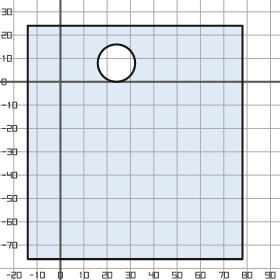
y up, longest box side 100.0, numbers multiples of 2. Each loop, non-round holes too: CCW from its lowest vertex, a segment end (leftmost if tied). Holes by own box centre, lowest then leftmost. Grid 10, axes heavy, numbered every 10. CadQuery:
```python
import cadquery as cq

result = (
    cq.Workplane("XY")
    .moveTo(-14.0, -76.0)
    .lineTo(78.0, -76.0)
    .lineTo(78.0, 24.0)
    .lineTo(-14.0, 24.0)
    .close()
    .moveTo(24.0, 8.0)
    .circle(8.0)
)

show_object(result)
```